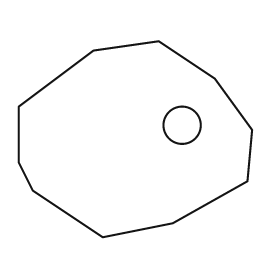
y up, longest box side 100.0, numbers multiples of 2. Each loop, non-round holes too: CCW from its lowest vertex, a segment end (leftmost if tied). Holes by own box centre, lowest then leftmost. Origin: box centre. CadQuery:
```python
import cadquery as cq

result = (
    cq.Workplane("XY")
    .moveTo(-14.0, -42.0)
    .lineTo(16.0, -36.0)
    .lineTo(48.0, -18.0)
    .lineTo(50.0, 4.0)
    .lineTo(34.0, 26.0)
    .lineTo(10.0, 42.0)
    .lineTo(-18.0, 38.0)
    .lineTo(-50.0, 14.0)
    .lineTo(-50.0, -10.0)
    .lineTo(-44.0, -22.0)
    .close()
    .moveTo(20.0, 6.0)
    .circle(8.0)
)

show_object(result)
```